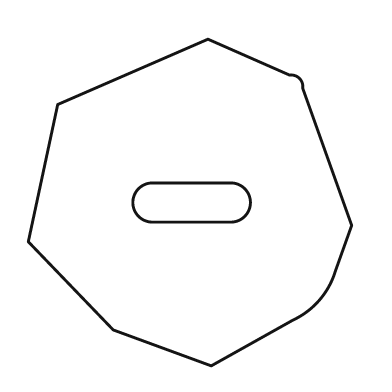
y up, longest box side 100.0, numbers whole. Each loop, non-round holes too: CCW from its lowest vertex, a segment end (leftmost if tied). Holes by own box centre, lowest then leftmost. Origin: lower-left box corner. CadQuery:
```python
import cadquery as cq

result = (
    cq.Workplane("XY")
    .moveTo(56.0, 0.0)
    .lineTo(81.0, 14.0)
    .threePointArc((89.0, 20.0), (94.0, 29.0))
    .lineTo(99.0, 43.0)
    .lineTo(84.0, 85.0)
    .threePointArc((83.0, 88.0), (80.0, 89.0))
    .lineTo(55.0, 100.0)
    .lineTo(9.0, 80.0)
    .lineTo(0.0, 38.0)
    .lineTo(26.0, 11.0)
    .close()
    .moveTo(38.0, 44.0)
    .lineTo(62.0, 44.0)
    .threePointArc((68.0, 50.0), (62.0, 56.0))
    .lineTo(38.0, 56.0)
    .threePointArc((32.0, 50.0), (38.0, 44.0))
    .close()
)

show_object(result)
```